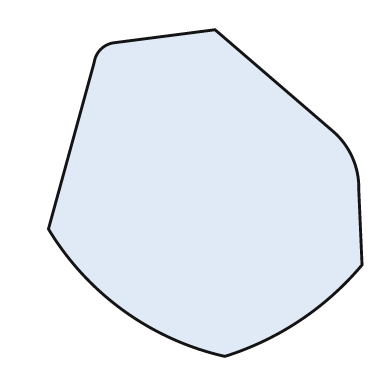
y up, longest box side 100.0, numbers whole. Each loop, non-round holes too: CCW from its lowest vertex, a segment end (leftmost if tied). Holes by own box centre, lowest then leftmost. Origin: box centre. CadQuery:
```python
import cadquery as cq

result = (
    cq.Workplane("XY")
    .moveTo(6.0, -50.0)
    .threePointArc((29.0, -39.0), (48.0, -22.0))
    .lineTo(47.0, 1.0)
    .threePointArc((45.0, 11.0), (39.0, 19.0))
    .lineTo(3.0, 50.0)
    .lineTo(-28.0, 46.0)
    .threePointArc((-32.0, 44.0), (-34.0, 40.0))
    .lineTo(-48.0, -11.0)
    .threePointArc((-25.0, -36.0), (6.0, -50.0))
    .close()
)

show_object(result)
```